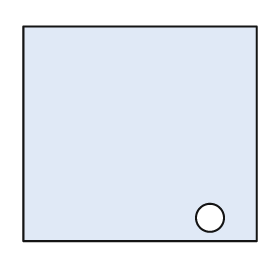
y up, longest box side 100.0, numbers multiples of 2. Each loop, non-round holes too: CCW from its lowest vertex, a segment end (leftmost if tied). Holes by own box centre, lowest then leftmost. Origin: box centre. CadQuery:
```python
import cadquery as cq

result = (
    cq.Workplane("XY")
    .moveTo(-50.0, -46.0)
    .lineTo(50.0, -46.0)
    .lineTo(50.0, 46.0)
    .lineTo(-50.0, 46.0)
    .close()
    .moveTo(30.0, -36.0)
    .circle(6.0)
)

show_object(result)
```